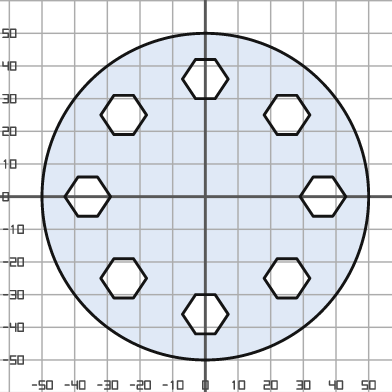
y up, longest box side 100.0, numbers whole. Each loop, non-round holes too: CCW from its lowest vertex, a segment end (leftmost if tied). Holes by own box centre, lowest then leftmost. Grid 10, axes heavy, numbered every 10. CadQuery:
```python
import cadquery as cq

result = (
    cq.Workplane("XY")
    .moveTo(0.0, 0.0)
    .circle(50.0)
    .moveTo(-3.0, -42.0)
    .lineTo(3.0, -42.0)
    .lineTo(7.0, -36.0)
    .lineTo(3.0, -30.0)
    .lineTo(-3.0, -30.0)
    .lineTo(-7.0, -36.0)
    .close()
    .moveTo(-28.0, -31.0)
    .lineTo(-22.0, -31.0)
    .lineTo(-18.0, -25.0)
    .lineTo(-22.0, -19.0)
    .lineTo(-28.0, -19.0)
    .lineTo(-32.0, -25.0)
    .close()
    .moveTo(22.0, -31.0)
    .lineTo(28.0, -31.0)
    .lineTo(32.0, -25.0)
    .lineTo(28.0, -19.0)
    .lineTo(22.0, -19.0)
    .lineTo(18.0, -25.0)
    .close()
    .moveTo(-39.0, -6.0)
    .lineTo(-33.0, -6.0)
    .lineTo(-29.0, 0.0)
    .lineTo(-33.0, 6.0)
    .lineTo(-39.0, 6.0)
    .lineTo(-43.0, 0.0)
    .close()
    .moveTo(33.0, -6.0)
    .lineTo(39.0, -6.0)
    .lineTo(43.0, 0.0)
    .lineTo(39.0, 6.0)
    .lineTo(33.0, 6.0)
    .lineTo(29.0, 0.0)
    .close()
    .moveTo(-28.0, 19.0)
    .lineTo(-22.0, 19.0)
    .lineTo(-18.0, 25.0)
    .lineTo(-22.0, 31.0)
    .lineTo(-28.0, 31.0)
    .lineTo(-32.0, 25.0)
    .close()
    .moveTo(22.0, 19.0)
    .lineTo(28.0, 19.0)
    .lineTo(32.0, 25.0)
    .lineTo(28.0, 31.0)
    .lineTo(22.0, 31.0)
    .lineTo(18.0, 25.0)
    .close()
    .moveTo(-3.0, 30.0)
    .lineTo(3.0, 30.0)
    .lineTo(7.0, 36.0)
    .lineTo(3.0, 42.0)
    .lineTo(-3.0, 42.0)
    .lineTo(-7.0, 36.0)
    .close()
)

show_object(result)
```